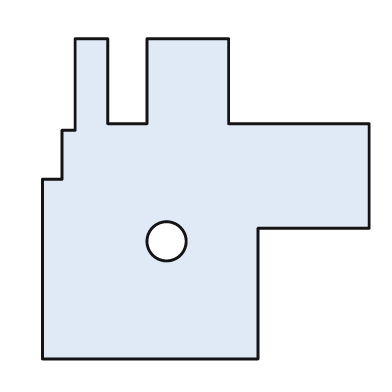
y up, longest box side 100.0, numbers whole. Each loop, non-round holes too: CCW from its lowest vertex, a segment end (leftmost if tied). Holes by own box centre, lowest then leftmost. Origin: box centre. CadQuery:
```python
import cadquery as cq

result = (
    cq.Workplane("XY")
    .moveTo(-50.0, -49.0)
    .lineTo(16.0, -49.0)
    .lineTo(16.0, -9.0)
    .lineTo(50.0, -9.0)
    .lineTo(50.0, 23.0)
    .lineTo(7.0, 23.0)
    .lineTo(7.0, 49.0)
    .lineTo(-18.0, 49.0)
    .lineTo(-18.0, 23.0)
    .lineTo(-30.0, 23.0)
    .lineTo(-30.0, 49.0)
    .lineTo(-40.0, 49.0)
    .lineTo(-40.0, 21.0)
    .lineTo(-44.0, 21.0)
    .lineTo(-44.0, 6.0)
    .lineTo(-50.0, 6.0)
    .close()
    .moveTo(-12.0, -13.0)
    .circle(6.0)
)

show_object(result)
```